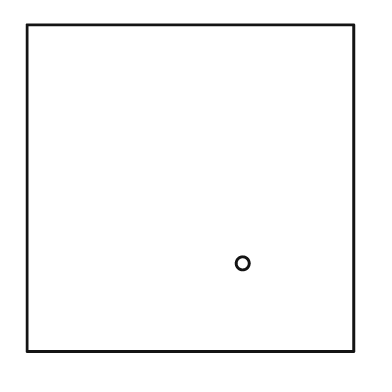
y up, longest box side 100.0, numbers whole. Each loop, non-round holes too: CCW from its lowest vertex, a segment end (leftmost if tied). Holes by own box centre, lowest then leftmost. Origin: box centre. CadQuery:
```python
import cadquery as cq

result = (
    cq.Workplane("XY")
    .moveTo(-50.0, -50.0)
    .lineTo(50.0, -50.0)
    .lineTo(50.0, 50.0)
    .lineTo(-50.0, 50.0)
    .close()
    .moveTo(16.0, -23.0)
    .circle(2.0)
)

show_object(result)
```